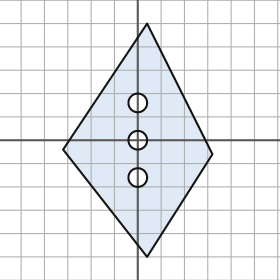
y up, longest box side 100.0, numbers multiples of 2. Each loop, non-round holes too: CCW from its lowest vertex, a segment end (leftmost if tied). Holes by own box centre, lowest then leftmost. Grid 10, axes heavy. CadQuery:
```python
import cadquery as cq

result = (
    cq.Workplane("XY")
    .moveTo(4.0, -50.0)
    .lineTo(32.0, -6.0)
    .lineTo(4.0, 50.0)
    .lineTo(-32.0, -4.0)
    .close()
    .moveTo(0.0, -16.0)
    .circle(4.0)
    .moveTo(0.0, 0.0)
    .circle(4.0)
    .moveTo(0.0, 16.0)
    .circle(4.0)
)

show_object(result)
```